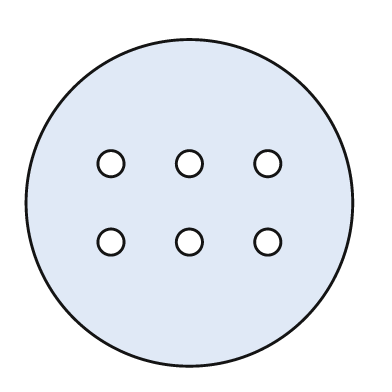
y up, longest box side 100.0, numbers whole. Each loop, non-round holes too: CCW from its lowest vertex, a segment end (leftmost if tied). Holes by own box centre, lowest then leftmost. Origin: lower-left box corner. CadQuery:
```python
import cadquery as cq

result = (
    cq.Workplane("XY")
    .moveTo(50.0, 50.0)
    .circle(50.0)
    .moveTo(26.0, 38.0)
    .circle(4.0)
    .moveTo(50.0, 38.0)
    .circle(4.0)
    .moveTo(74.0, 38.0)
    .circle(4.0)
    .moveTo(26.0, 62.0)
    .circle(4.0)
    .moveTo(50.0, 62.0)
    .circle(4.0)
    .moveTo(74.0, 62.0)
    .circle(4.0)
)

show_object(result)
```